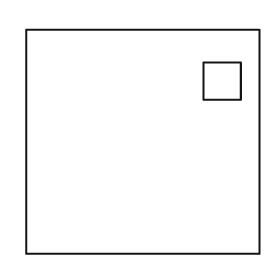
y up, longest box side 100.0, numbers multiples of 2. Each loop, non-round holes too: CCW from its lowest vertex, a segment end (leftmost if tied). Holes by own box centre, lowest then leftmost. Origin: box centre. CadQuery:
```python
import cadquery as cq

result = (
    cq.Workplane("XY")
    .moveTo(-50.0, -48.0)
    .lineTo(50.0, -48.0)
    .lineTo(50.0, 48.0)
    .lineTo(-50.0, 48.0)
    .close()
    .moveTo(26.0, 18.0)
    .lineTo(42.0, 18.0)
    .lineTo(42.0, 34.0)
    .lineTo(26.0, 34.0)
    .close()
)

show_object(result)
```